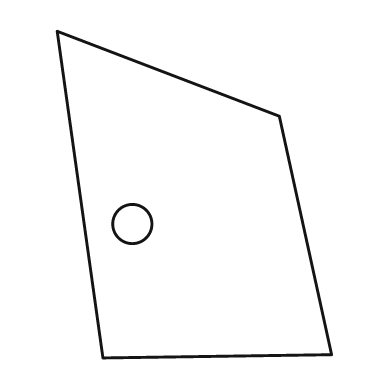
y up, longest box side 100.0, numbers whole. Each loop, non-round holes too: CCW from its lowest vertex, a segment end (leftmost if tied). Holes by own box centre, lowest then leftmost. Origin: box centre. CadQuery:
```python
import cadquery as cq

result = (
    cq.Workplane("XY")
    .moveTo(-28.0, -50.0)
    .lineTo(42.0, -49.0)
    .lineTo(26.0, 24.0)
    .lineTo(-42.0, 50.0)
    .close()
    .moveTo(-19.0, -9.0)
    .circle(6.0)
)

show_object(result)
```